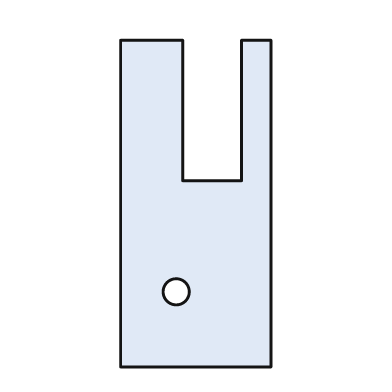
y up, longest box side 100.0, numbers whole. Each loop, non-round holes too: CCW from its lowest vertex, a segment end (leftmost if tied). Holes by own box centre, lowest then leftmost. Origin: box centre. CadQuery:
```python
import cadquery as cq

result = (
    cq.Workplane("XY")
    .moveTo(-23.0, -50.0)
    .lineTo(23.0, -50.0)
    .lineTo(23.0, 50.0)
    .lineTo(14.0, 50.0)
    .lineTo(14.0, 7.0)
    .lineTo(-4.0, 7.0)
    .lineTo(-4.0, 50.0)
    .lineTo(-23.0, 50.0)
    .close()
    .moveTo(-6.0, -27.0)
    .circle(4.0)
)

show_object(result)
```